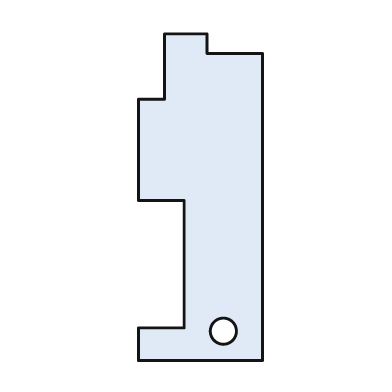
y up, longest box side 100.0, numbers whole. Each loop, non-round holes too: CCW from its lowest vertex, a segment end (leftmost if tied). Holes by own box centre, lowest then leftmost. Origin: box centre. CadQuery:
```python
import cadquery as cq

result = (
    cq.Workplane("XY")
    .moveTo(-19.0, -50.0)
    .lineTo(19.0, -50.0)
    .lineTo(19.0, 44.0)
    .lineTo(2.0, 44.0)
    .lineTo(2.0, 50.0)
    .lineTo(-11.0, 50.0)
    .lineTo(-11.0, 30.0)
    .lineTo(-19.0, 30.0)
    .lineTo(-19.0, -1.0)
    .lineTo(-5.0, -1.0)
    .lineTo(-5.0, -40.0)
    .lineTo(-19.0, -40.0)
    .close()
    .moveTo(7.0, -41.0)
    .circle(4.0)
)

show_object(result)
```